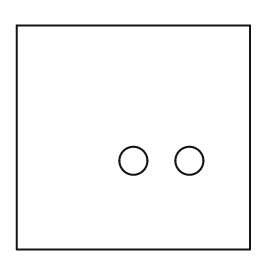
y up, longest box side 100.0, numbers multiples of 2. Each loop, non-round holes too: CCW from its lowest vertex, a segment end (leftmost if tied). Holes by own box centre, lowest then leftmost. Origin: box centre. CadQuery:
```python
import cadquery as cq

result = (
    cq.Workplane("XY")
    .moveTo(-50.0, -48.0)
    .lineTo(50.0, -48.0)
    .lineTo(50.0, 48.0)
    .lineTo(-50.0, 48.0)
    .close()
    .moveTo(0.0, -10.0)
    .circle(6.0)
    .moveTo(24.0, -10.0)
    .circle(6.0)
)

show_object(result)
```